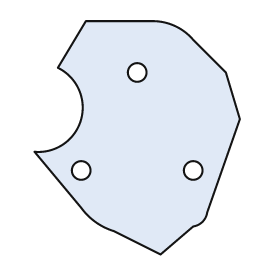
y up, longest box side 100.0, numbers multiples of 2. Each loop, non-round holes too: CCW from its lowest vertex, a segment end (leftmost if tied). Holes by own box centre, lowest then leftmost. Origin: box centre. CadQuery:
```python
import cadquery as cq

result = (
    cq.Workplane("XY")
    .moveTo(10.0, -50.0)
    .lineTo(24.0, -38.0)
    .threePointArc((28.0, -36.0), (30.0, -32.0))
    .lineTo(44.0, 8.0)
    .lineTo(38.0, 28.0)
    .lineTo(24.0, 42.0)
    .threePointArc((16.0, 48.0), (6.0, 50.0))
    .lineTo(-22.0, 50.0)
    .lineTo(-34.0, 30.0)
    .threePointArc((-24.0, 8.0), (-44.0, -6.0))
    .lineTo(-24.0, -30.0)
    .threePointArc((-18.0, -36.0), (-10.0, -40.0))
    .close()
    .moveTo(-24.0, -14.0)
    .circle(4.0)
    .moveTo(24.0, -14.0)
    .circle(4.0)
    .moveTo(0.0, 28.0)
    .circle(4.0)
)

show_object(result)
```